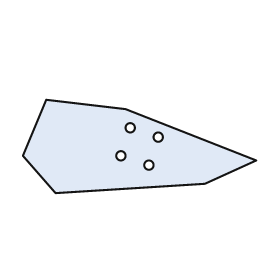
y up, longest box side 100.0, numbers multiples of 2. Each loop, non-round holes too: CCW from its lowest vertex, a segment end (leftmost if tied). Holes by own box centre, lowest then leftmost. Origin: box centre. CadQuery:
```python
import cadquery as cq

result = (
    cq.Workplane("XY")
    .moveTo(-36.0, -20.0)
    .lineTo(28.0, -16.0)
    .lineTo(50.0, -6.0)
    .lineTo(-6.0, 16.0)
    .lineTo(-40.0, 20.0)
    .lineTo(-50.0, -4.0)
    .close()
    .moveTo(4.0, -8.0)
    .circle(2.0)
    .moveTo(-8.0, -4.0)
    .circle(2.0)
    .moveTo(8.0, 4.0)
    .circle(2.0)
    .moveTo(-4.0, 8.0)
    .circle(2.0)
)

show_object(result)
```